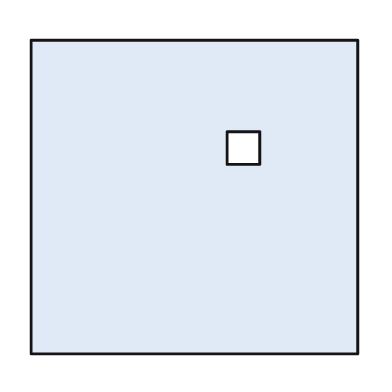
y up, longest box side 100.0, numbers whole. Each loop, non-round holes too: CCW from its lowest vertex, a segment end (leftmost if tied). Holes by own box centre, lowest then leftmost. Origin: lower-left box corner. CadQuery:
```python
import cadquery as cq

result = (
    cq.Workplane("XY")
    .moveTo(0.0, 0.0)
    .lineTo(100.0, 0.0)
    .lineTo(100.0, 96.0)
    .lineTo(0.0, 96.0)
    .close()
    .moveTo(60.0, 58.0)
    .lineTo(70.0, 58.0)
    .lineTo(70.0, 68.0)
    .lineTo(60.0, 68.0)
    .close()
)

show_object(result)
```